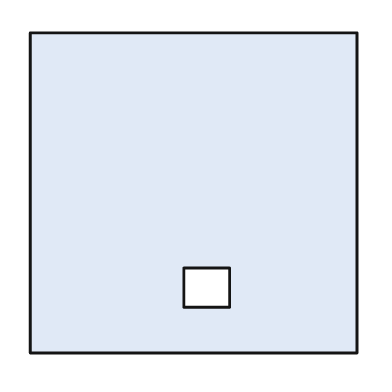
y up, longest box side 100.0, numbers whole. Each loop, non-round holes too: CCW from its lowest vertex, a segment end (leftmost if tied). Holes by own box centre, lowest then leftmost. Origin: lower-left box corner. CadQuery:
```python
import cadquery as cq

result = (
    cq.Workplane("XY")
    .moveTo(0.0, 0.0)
    .lineTo(100.0, 0.0)
    .lineTo(100.0, 98.0)
    .lineTo(0.0, 98.0)
    .close()
    .moveTo(47.0, 14.0)
    .lineTo(61.0, 14.0)
    .lineTo(61.0, 26.0)
    .lineTo(47.0, 26.0)
    .close()
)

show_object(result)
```